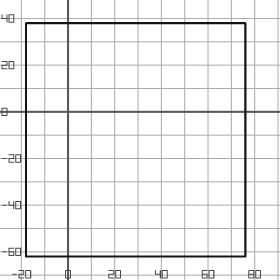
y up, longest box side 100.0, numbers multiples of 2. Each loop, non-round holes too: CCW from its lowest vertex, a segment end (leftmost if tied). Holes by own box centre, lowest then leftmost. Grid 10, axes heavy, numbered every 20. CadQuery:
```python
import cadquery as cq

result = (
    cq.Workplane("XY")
    .moveTo(-18.0, -62.0)
    .lineTo(76.0, -62.0)
    .lineTo(76.0, 38.0)
    .lineTo(-18.0, 38.0)
    .close()
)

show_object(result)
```